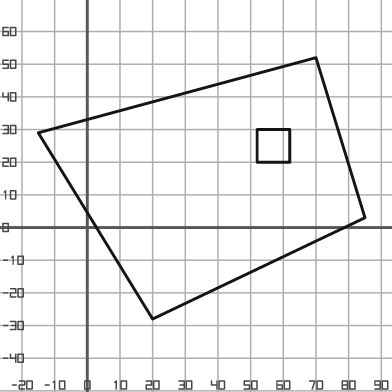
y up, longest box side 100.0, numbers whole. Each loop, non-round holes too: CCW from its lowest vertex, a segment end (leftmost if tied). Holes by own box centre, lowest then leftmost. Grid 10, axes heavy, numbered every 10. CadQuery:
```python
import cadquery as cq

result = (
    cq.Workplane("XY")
    .moveTo(20.0, -28.0)
    .lineTo(85.0, 3.0)
    .lineTo(70.0, 52.0)
    .lineTo(-15.0, 29.0)
    .close()
    .moveTo(52.0, 20.0)
    .lineTo(62.0, 20.0)
    .lineTo(62.0, 30.0)
    .lineTo(52.0, 30.0)
    .close()
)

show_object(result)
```